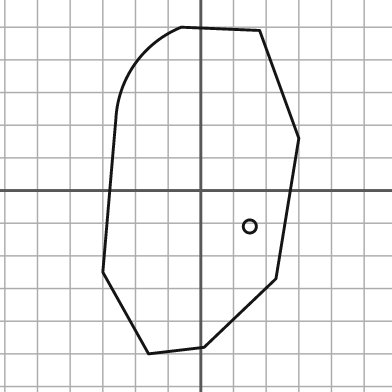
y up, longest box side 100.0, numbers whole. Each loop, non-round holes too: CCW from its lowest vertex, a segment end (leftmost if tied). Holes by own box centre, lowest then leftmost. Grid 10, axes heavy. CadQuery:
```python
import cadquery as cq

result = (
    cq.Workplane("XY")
    .moveTo(-16.0, -50.0)
    .lineTo(1.0, -48.0)
    .lineTo(23.0, -27.0)
    .lineTo(30.0, 16.0)
    .lineTo(18.0, 49.0)
    .lineTo(-6.0, 50.0)
    .threePointArc((-20.0, 39.0), (-26.0, 22.0))
    .lineTo(-30.0, -25.0)
    .close()
    .moveTo(15.0, -11.0)
    .circle(2.0)
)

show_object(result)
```